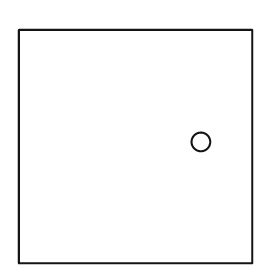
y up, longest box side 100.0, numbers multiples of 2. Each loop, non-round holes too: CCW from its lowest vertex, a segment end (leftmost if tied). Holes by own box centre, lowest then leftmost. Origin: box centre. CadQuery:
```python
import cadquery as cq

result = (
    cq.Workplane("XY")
    .moveTo(-50.0, -50.0)
    .lineTo(50.0, -50.0)
    .lineTo(50.0, 50.0)
    .lineTo(-50.0, 50.0)
    .close()
    .moveTo(28.0, 2.0)
    .circle(4.0)
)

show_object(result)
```